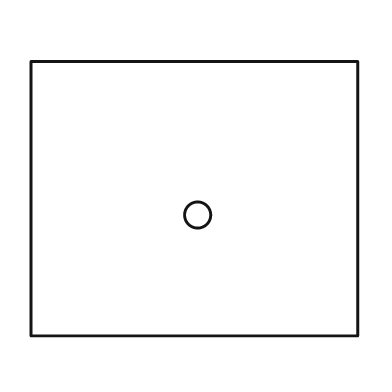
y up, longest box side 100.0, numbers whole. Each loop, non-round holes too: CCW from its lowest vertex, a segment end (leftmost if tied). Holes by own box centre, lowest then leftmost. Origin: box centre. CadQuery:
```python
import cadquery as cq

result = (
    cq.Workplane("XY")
    .moveTo(-50.0, -42.0)
    .lineTo(50.0, -42.0)
    .lineTo(50.0, 42.0)
    .lineTo(-50.0, 42.0)
    .close()
    .moveTo(1.0, -5.0)
    .circle(4.0)
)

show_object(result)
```